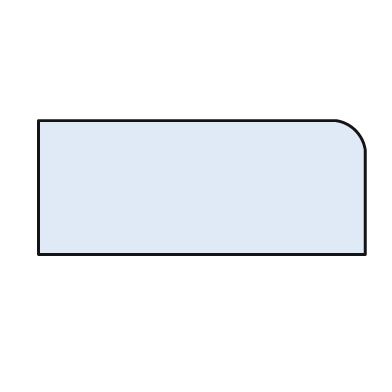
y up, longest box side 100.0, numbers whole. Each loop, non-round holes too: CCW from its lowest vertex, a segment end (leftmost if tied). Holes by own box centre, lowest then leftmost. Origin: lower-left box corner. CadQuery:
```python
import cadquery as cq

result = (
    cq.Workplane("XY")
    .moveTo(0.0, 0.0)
    .lineTo(100.0, 0.0)
    .lineTo(100.0, 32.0)
    .threePointArc((97.0, 38.0), (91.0, 41.0))
    .lineTo(0.0, 41.0)
    .close()
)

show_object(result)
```